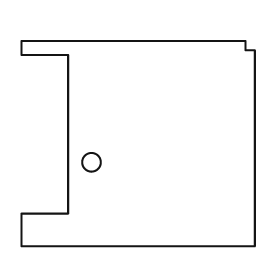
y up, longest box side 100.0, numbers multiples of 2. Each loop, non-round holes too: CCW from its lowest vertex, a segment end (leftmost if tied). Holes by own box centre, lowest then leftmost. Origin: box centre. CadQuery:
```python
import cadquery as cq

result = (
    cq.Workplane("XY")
    .moveTo(-50.0, -44.0)
    .lineTo(50.0, -44.0)
    .lineTo(50.0, 40.0)
    .lineTo(46.0, 40.0)
    .lineTo(46.0, 44.0)
    .lineTo(-50.0, 44.0)
    .lineTo(-50.0, 38.0)
    .lineTo(-30.0, 38.0)
    .lineTo(-30.0, -30.0)
    .lineTo(-50.0, -30.0)
    .close()
    .moveTo(-20.0, -8.0)
    .circle(4.0)
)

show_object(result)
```